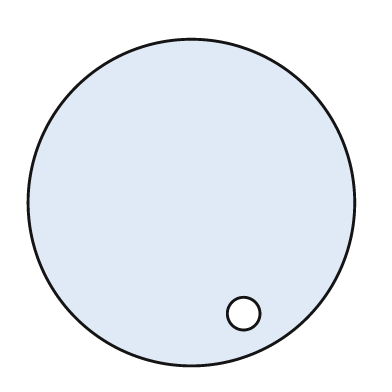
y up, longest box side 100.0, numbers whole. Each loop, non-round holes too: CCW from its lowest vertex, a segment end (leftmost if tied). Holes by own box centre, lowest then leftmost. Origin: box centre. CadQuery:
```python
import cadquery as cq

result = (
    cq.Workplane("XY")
    .moveTo(0.0, 0.0)
    .circle(50.0)
    .moveTo(16.0, -34.0)
    .circle(5.0)
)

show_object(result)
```